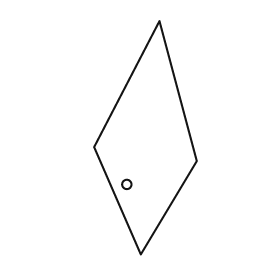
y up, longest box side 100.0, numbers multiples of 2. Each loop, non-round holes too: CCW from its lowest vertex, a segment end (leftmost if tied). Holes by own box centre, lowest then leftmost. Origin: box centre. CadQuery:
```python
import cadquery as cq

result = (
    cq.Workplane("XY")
    .moveTo(-2.0, -50.0)
    .lineTo(22.0, -10.0)
    .lineTo(6.0, 50.0)
    .lineTo(-22.0, -4.0)
    .close()
    .moveTo(-8.0, -20.0)
    .circle(2.0)
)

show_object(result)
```